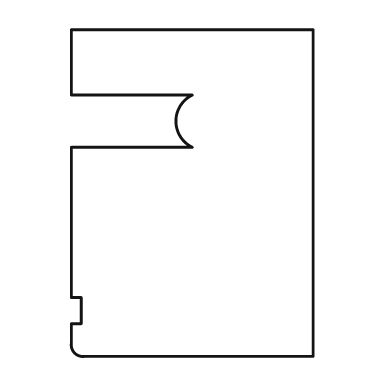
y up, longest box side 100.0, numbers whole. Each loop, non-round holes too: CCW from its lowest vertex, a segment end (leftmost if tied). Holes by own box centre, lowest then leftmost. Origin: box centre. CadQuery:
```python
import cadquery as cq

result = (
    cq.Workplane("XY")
    .moveTo(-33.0, -50.0)
    .lineTo(37.0, -50.0)
    .lineTo(37.0, 50.0)
    .lineTo(-37.0, 50.0)
    .lineTo(-37.0, 30.0)
    .lineTo(0.0, 30.0)
    .threePointArc((-5.0, 22.0), (0.0, 14.0))
    .lineTo(-37.0, 14.0)
    .lineTo(-37.0, -32.0)
    .lineTo(-34.0, -32.0)
    .lineTo(-34.0, -40.0)
    .lineTo(-37.0, -40.0)
    .lineTo(-37.0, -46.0)
    .threePointArc((-36.0, -49.0), (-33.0, -50.0))
    .close()
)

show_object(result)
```